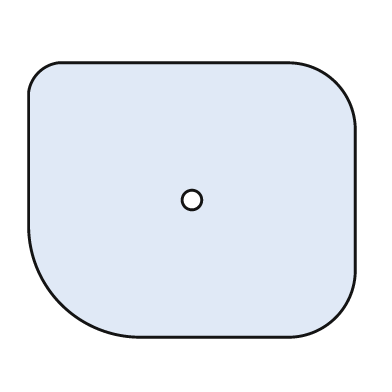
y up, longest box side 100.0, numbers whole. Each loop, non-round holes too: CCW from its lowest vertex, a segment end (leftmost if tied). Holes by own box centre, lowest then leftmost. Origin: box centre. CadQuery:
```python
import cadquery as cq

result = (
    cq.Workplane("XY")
    .moveTo(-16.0, -42.0)
    .lineTo(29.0, -42.0)
    .threePointArc((44.0, -36.0), (50.0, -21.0))
    .lineTo(50.0, 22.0)
    .threePointArc((44.0, 36.0), (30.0, 42.0))
    .lineTo(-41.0, 42.0)
    .threePointArc((-47.0, 39.0), (-50.0, 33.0))
    .lineTo(-50.0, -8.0)
    .threePointArc((-40.0, -32.0), (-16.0, -42.0))
    .close()
    .moveTo(0.0, 0.0)
    .circle(3.0)
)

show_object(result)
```